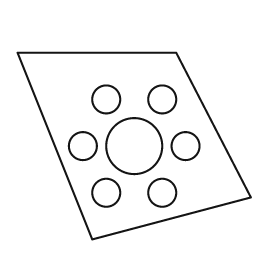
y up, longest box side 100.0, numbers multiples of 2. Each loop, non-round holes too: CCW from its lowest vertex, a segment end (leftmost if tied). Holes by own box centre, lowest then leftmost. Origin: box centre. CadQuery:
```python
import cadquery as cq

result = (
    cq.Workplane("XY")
    .moveTo(-18.0, -40.0)
    .lineTo(50.0, -22.0)
    .lineTo(18.0, 40.0)
    .lineTo(-50.0, 40.0)
    .close()
    .moveTo(-12.0, -20.0)
    .circle(6.0)
    .moveTo(12.0, -20.0)
    .circle(6.0)
    .moveTo(-22.0, 0.0)
    .circle(6.0)
    .moveTo(0.0, 0.0)
    .circle(12.0)
    .moveTo(22.0, 0.0)
    .circle(6.0)
    .moveTo(-12.0, 20.0)
    .circle(6.0)
    .moveTo(12.0, 20.0)
    .circle(6.0)
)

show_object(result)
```